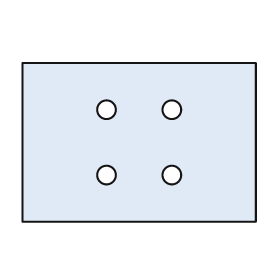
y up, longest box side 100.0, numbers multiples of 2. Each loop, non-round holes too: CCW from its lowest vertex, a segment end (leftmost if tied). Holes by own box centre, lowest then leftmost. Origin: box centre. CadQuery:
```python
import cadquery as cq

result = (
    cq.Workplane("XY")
    .moveTo(-50.0, -34.0)
    .lineTo(50.0, -34.0)
    .lineTo(50.0, 34.0)
    .lineTo(-50.0, 34.0)
    .close()
    .moveTo(-14.0, -14.0)
    .circle(4.0)
    .moveTo(14.0, -14.0)
    .circle(4.0)
    .moveTo(-14.0, 14.0)
    .circle(4.0)
    .moveTo(14.0, 14.0)
    .circle(4.0)
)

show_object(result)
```